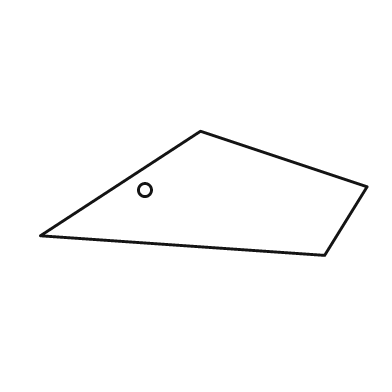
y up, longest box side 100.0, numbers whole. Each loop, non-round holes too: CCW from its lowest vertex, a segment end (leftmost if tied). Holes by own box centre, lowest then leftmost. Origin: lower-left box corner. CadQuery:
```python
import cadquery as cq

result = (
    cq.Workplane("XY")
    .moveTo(87.0, 0.0)
    .lineTo(100.0, 21.0)
    .lineTo(49.0, 38.0)
    .lineTo(0.0, 6.0)
    .close()
    .moveTo(32.0, 20.0)
    .circle(2.0)
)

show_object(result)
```